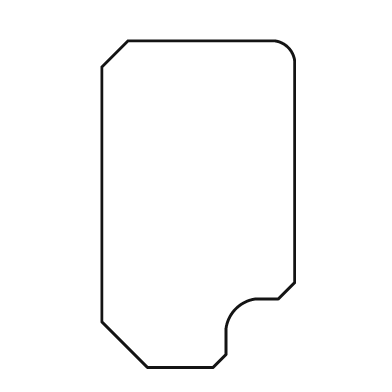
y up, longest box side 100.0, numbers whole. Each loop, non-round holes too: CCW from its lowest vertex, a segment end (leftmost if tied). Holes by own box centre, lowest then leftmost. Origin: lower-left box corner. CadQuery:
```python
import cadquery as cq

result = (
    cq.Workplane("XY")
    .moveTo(14.0, 0.0)
    .lineTo(34.0, 0.0)
    .lineTo(38.0, 4.0)
    .lineTo(38.0, 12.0)
    .threePointArc((41.0, 18.0), (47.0, 21.0))
    .lineTo(54.0, 21.0)
    .lineTo(59.0, 26.0)
    .lineTo(59.0, 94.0)
    .threePointArc((57.0, 98.0), (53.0, 100.0))
    .lineTo(8.0, 100.0)
    .lineTo(0.0, 92.0)
    .lineTo(0.0, 14.0)
    .close()
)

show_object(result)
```